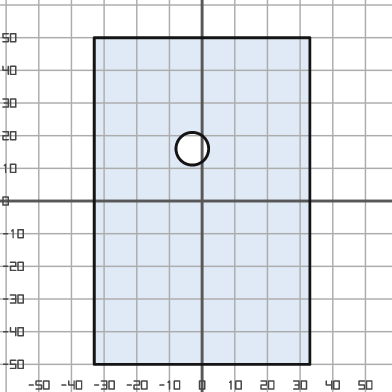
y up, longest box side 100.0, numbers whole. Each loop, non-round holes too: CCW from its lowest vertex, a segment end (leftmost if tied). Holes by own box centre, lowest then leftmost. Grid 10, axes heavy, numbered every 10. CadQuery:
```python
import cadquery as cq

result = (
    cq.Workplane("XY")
    .moveTo(-33.0, -50.0)
    .lineTo(33.0, -50.0)
    .lineTo(33.0, 50.0)
    .lineTo(-33.0, 50.0)
    .close()
    .moveTo(-3.0, 16.0)
    .circle(5.0)
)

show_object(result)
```